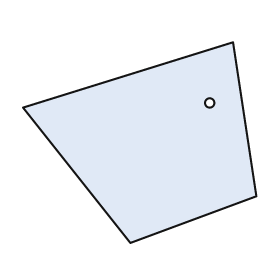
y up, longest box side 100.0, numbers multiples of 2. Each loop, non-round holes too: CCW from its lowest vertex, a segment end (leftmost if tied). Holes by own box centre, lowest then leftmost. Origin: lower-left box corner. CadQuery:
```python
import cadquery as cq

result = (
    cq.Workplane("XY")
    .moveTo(46.0, 0.0)
    .lineTo(100.0, 20.0)
    .lineTo(90.0, 86.0)
    .lineTo(0.0, 58.0)
    .close()
    .moveTo(80.0, 60.0)
    .circle(2.0)
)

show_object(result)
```